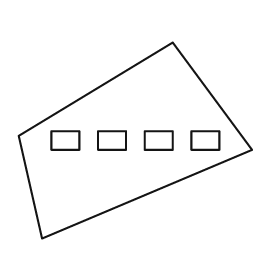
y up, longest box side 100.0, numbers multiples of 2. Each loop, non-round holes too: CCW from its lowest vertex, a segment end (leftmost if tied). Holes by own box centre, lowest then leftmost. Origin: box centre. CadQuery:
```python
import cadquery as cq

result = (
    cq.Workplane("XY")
    .moveTo(-40.0, -42.0)
    .lineTo(50.0, -4.0)
    .lineTo(16.0, 42.0)
    .lineTo(-50.0, 2.0)
    .close()
    .moveTo(-36.0, -4.0)
    .lineTo(-24.0, -4.0)
    .lineTo(-24.0, 4.0)
    .lineTo(-36.0, 4.0)
    .close()
    .moveTo(-16.0, -4.0)
    .lineTo(-4.0, -4.0)
    .lineTo(-4.0, 4.0)
    .lineTo(-16.0, 4.0)
    .close()
    .moveTo(4.0, -4.0)
    .lineTo(16.0, -4.0)
    .lineTo(16.0, 4.0)
    .lineTo(4.0, 4.0)
    .close()
    .moveTo(24.0, -4.0)
    .lineTo(36.0, -4.0)
    .lineTo(36.0, 4.0)
    .lineTo(24.0, 4.0)
    .close()
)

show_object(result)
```